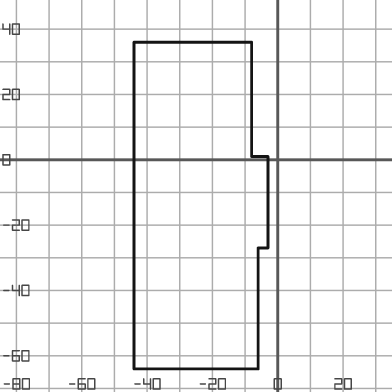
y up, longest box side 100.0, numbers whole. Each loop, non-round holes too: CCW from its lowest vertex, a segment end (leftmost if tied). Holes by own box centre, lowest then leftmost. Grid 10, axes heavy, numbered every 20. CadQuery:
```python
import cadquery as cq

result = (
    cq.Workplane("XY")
    .moveTo(-44.0, -64.0)
    .lineTo(-6.0, -64.0)
    .lineTo(-6.0, -27.0)
    .lineTo(-3.0, -27.0)
    .lineTo(-3.0, 1.0)
    .lineTo(-8.0, 1.0)
    .lineTo(-8.0, 36.0)
    .lineTo(-44.0, 36.0)
    .close()
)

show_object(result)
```